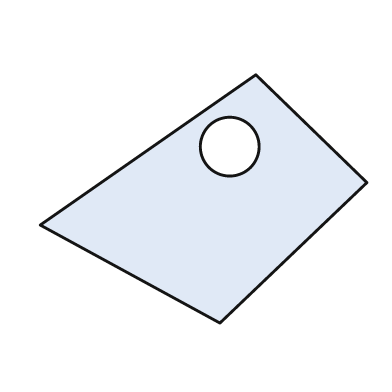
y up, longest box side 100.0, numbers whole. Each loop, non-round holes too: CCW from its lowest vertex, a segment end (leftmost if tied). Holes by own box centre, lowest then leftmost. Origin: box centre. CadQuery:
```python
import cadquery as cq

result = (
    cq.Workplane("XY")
    .moveTo(5.0, -38.0)
    .lineTo(50.0, 5.0)
    .lineTo(16.0, 38.0)
    .lineTo(-50.0, -8.0)
    .close()
    .moveTo(8.0, 16.0)
    .circle(9.0)
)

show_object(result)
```